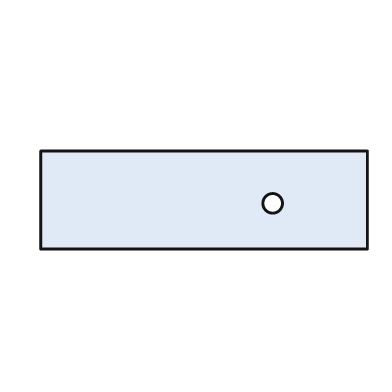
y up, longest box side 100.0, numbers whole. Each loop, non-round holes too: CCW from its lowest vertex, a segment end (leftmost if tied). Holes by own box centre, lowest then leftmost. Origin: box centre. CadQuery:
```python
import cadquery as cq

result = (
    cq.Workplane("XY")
    .moveTo(-50.0, -15.0)
    .lineTo(50.0, -15.0)
    .lineTo(50.0, 15.0)
    .lineTo(-50.0, 15.0)
    .close()
    .moveTo(21.0, -1.0)
    .circle(3.0)
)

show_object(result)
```